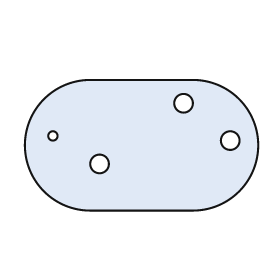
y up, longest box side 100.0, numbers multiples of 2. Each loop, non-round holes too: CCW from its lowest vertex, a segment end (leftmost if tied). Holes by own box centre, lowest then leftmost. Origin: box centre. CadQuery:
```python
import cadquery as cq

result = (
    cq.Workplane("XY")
    .moveTo(-22.0, -28.0)
    .lineTo(22.0, -28.0)
    .threePointArc((50.0, 0.0), (22.0, 28.0))
    .lineTo(-22.0, 28.0)
    .threePointArc((-50.0, 0.0), (-22.0, -28.0))
    .close()
    .moveTo(-18.0, -8.0)
    .circle(4.0)
    .moveTo(38.0, 2.0)
    .circle(4.0)
    .moveTo(-38.0, 4.0)
    .circle(2.0)
    .moveTo(18.0, 18.0)
    .circle(4.0)
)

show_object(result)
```